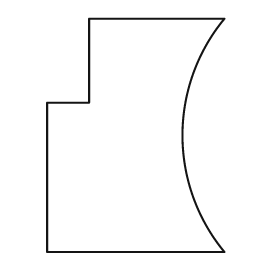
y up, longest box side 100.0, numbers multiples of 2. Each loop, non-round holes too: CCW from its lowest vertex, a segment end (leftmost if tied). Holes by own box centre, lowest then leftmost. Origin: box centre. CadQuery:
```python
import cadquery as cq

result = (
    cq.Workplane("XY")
    .moveTo(-38.0, -50.0)
    .lineTo(38.0, -50.0)
    .threePointArc((20.0, 0.0), (38.0, 50.0))
    .lineTo(-20.0, 50.0)
    .lineTo(-20.0, 14.0)
    .lineTo(-38.0, 14.0)
    .close()
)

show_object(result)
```